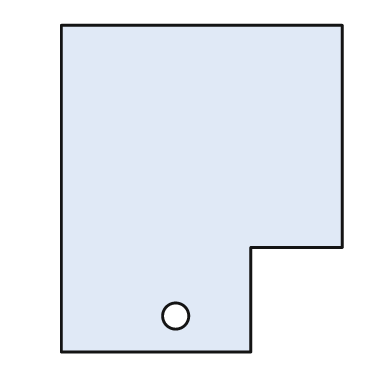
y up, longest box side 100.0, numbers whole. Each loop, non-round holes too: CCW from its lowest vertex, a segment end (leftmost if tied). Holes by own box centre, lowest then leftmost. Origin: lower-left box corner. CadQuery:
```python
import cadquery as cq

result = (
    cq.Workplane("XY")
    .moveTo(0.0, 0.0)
    .lineTo(58.0, 0.0)
    .lineTo(58.0, 32.0)
    .lineTo(86.0, 32.0)
    .lineTo(86.0, 100.0)
    .lineTo(0.0, 100.0)
    .close()
    .moveTo(35.0, 11.0)
    .circle(4.0)
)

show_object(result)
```